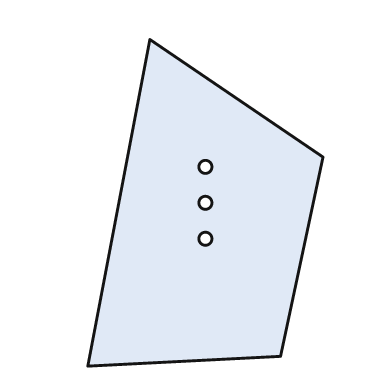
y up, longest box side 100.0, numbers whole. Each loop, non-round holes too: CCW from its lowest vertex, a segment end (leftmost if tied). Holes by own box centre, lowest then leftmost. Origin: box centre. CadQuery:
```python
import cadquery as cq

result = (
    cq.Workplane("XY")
    .moveTo(-36.0, -50.0)
    .lineTo(23.0, -47.0)
    .lineTo(36.0, 14.0)
    .lineTo(-17.0, 50.0)
    .close()
    .moveTo(0.0, -11.0)
    .circle(2.0)
    .moveTo(0.0, 0.0)
    .circle(2.0)
    .moveTo(0.0, 11.0)
    .circle(2.0)
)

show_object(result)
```